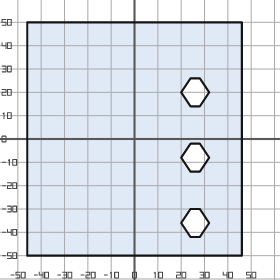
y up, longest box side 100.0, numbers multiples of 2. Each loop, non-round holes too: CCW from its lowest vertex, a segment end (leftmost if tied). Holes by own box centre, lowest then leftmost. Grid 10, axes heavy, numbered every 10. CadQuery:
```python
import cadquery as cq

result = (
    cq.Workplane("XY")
    .moveTo(-46.0, -50.0)
    .lineTo(46.0, -50.0)
    .lineTo(46.0, 50.0)
    .lineTo(-46.0, 50.0)
    .close()
    .moveTo(24.0, -42.0)
    .lineTo(28.0, -42.0)
    .lineTo(32.0, -36.0)
    .lineTo(28.0, -30.0)
    .lineTo(24.0, -30.0)
    .lineTo(20.0, -36.0)
    .close()
    .moveTo(24.0, -14.0)
    .lineTo(28.0, -14.0)
    .lineTo(32.0, -8.0)
    .lineTo(28.0, -2.0)
    .lineTo(24.0, -2.0)
    .lineTo(20.0, -8.0)
    .close()
    .moveTo(24.0, 14.0)
    .lineTo(28.0, 14.0)
    .lineTo(32.0, 20.0)
    .lineTo(28.0, 26.0)
    .lineTo(24.0, 26.0)
    .lineTo(20.0, 20.0)
    .close()
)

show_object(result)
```